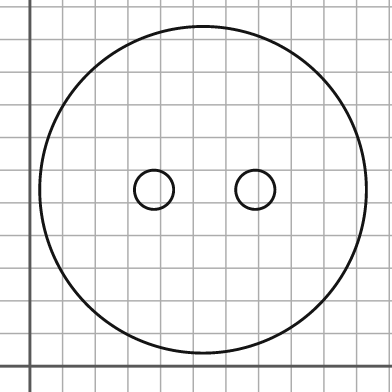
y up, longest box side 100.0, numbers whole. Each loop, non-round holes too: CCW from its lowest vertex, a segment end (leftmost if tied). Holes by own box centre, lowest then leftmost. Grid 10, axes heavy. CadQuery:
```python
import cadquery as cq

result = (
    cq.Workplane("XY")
    .moveTo(53.0, 54.0)
    .circle(50.0)
    .moveTo(38.0, 54.0)
    .circle(6.0)
    .moveTo(69.0, 54.0)
    .circle(6.0)
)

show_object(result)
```